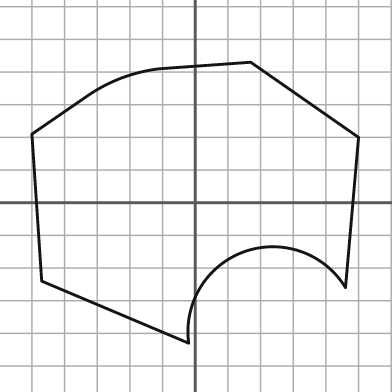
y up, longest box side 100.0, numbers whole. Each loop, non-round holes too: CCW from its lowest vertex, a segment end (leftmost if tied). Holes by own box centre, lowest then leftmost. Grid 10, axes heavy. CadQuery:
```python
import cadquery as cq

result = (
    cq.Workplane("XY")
    .moveTo(-2.0, -43.0)
    .threePointArc((15.0, -15.0), (46.0, -26.0))
    .lineTo(50.0, 20.0)
    .lineTo(17.0, 43.0)
    .lineTo(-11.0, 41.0)
    .threePointArc((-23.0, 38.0), (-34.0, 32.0))
    .lineTo(-50.0, 21.0)
    .lineTo(-47.0, -24.0)
    .close()
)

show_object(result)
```